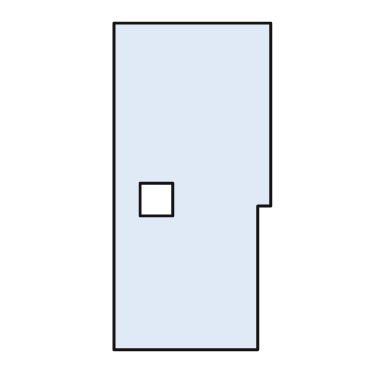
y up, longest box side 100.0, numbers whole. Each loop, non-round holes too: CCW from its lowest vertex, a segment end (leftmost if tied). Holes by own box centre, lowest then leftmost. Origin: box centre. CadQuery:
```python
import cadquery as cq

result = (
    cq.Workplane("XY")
    .moveTo(-24.0, -50.0)
    .lineTo(20.0, -50.0)
    .lineTo(20.0, -6.0)
    .lineTo(24.0, -6.0)
    .lineTo(24.0, 50.0)
    .lineTo(-24.0, 50.0)
    .close()
    .moveTo(-16.0, -9.0)
    .lineTo(-6.0, -9.0)
    .lineTo(-6.0, 1.0)
    .lineTo(-16.0, 1.0)
    .close()
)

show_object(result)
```